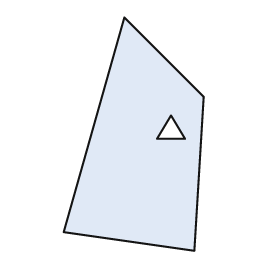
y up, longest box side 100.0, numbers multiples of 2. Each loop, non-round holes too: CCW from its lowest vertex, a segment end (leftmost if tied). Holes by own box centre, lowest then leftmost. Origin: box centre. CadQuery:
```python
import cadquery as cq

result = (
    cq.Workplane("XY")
    .moveTo(26.0, -50.0)
    .lineTo(30.0, 16.0)
    .lineTo(-4.0, 50.0)
    .lineTo(-30.0, -42.0)
    .close()
    .moveTo(10.0, -2.0)
    .lineTo(22.0, -2.0)
    .lineTo(16.0, 8.0)
    .close()
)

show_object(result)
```